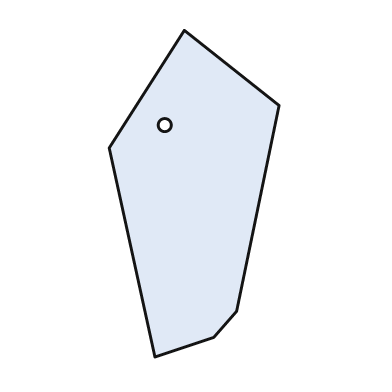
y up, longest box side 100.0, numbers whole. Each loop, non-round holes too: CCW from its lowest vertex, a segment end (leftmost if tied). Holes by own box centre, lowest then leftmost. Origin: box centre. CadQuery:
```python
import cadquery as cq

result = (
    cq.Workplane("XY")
    .moveTo(-12.0, -50.0)
    .lineTo(6.0, -44.0)
    .lineTo(13.0, -36.0)
    .lineTo(26.0, 27.0)
    .lineTo(-3.0, 50.0)
    .lineTo(-26.0, 14.0)
    .close()
    .moveTo(-9.0, 21.0)
    .circle(2.0)
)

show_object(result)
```